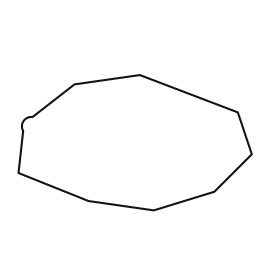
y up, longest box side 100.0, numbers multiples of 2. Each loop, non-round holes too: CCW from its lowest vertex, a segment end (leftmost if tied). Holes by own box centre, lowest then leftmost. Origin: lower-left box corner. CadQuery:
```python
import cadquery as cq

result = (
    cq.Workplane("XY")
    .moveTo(58.0, 0.0)
    .lineTo(84.0, 8.0)
    .lineTo(100.0, 24.0)
    .lineTo(94.0, 42.0)
    .lineTo(52.0, 58.0)
    .lineTo(24.0, 54.0)
    .lineTo(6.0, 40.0)
    .threePointArc((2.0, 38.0), (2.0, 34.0))
    .lineTo(0.0, 16.0)
    .lineTo(30.0, 4.0)
    .close()
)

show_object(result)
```